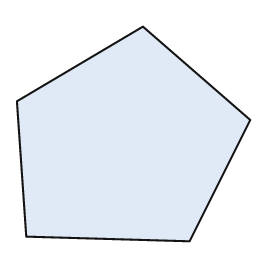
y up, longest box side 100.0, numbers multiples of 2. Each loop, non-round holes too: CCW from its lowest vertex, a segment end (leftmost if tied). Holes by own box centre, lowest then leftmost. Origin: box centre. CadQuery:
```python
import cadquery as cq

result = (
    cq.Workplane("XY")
    .moveTo(24.0, -46.0)
    .lineTo(50.0, 6.0)
    .lineTo(4.0, 46.0)
    .lineTo(-50.0, 14.0)
    .lineTo(-46.0, -44.0)
    .close()
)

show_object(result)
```